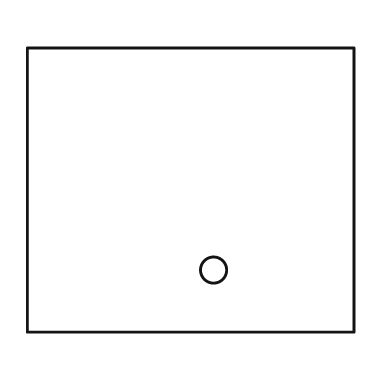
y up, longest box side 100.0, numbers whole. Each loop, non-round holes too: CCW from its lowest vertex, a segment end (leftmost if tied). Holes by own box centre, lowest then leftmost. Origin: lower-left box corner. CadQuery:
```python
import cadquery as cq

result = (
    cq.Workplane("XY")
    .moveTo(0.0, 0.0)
    .lineTo(100.0, 0.0)
    .lineTo(100.0, 87.0)
    .lineTo(0.0, 87.0)
    .close()
    .moveTo(57.0, 19.0)
    .circle(4.0)
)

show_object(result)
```